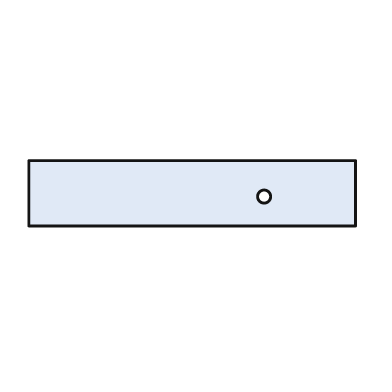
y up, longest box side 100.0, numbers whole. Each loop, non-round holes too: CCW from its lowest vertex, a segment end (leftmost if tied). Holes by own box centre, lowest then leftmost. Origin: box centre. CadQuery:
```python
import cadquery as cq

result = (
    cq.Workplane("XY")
    .moveTo(-50.0, -10.0)
    .lineTo(50.0, -10.0)
    .lineTo(50.0, 10.0)
    .lineTo(-50.0, 10.0)
    .close()
    .moveTo(22.0, -1.0)
    .circle(2.0)
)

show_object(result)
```